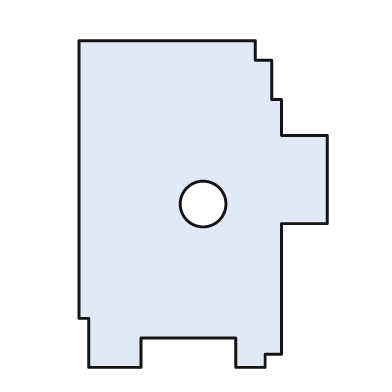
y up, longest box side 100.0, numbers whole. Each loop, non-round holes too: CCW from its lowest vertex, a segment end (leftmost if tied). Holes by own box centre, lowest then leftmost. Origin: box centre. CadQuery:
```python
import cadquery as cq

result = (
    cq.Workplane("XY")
    .moveTo(-35.0, -50.0)
    .lineTo(-19.0, -50.0)
    .lineTo(-19.0, -41.0)
    .lineTo(10.0, -41.0)
    .lineTo(10.0, -50.0)
    .lineTo(19.0, -50.0)
    .lineTo(19.0, -46.0)
    .lineTo(24.0, -46.0)
    .lineTo(24.0, -6.0)
    .lineTo(38.0, -6.0)
    .lineTo(38.0, 21.0)
    .lineTo(24.0, 21.0)
    .lineTo(24.0, 32.0)
    .lineTo(21.0, 32.0)
    .lineTo(21.0, 44.0)
    .lineTo(16.0, 44.0)
    .lineTo(16.0, 50.0)
    .lineTo(-38.0, 50.0)
    .lineTo(-38.0, -35.0)
    .lineTo(-35.0, -35.0)
    .close()
    .moveTo(0.0, 0.0)
    .circle(7.0)
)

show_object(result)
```